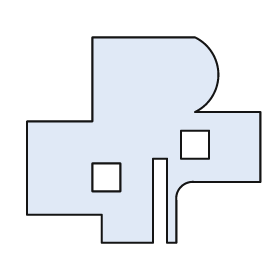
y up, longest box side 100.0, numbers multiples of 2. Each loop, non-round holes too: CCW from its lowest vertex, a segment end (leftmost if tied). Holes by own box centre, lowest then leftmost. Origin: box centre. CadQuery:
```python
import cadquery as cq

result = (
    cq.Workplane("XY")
    .moveTo(-18.0, -44.0)
    .lineTo(4.0, -44.0)
    .lineTo(4.0, -8.0)
    .lineTo(10.0, -8.0)
    .lineTo(10.0, -44.0)
    .lineTo(14.0, -44.0)
    .lineTo(14.0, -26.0)
    .threePointArc((16.0, -20.0), (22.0, -18.0))
    .lineTo(50.0, -18.0)
    .lineTo(50.0, 12.0)
    .lineTo(22.0, 12.0)
    .threePointArc((32.0, 28.0), (22.0, 44.0))
    .lineTo(-22.0, 44.0)
    .lineTo(-22.0, 8.0)
    .lineTo(-50.0, 8.0)
    .lineTo(-50.0, -32.0)
    .lineTo(-18.0, -32.0)
    .close()
    .moveTo(-22.0, -22.0)
    .lineTo(-10.0, -22.0)
    .lineTo(-10.0, -10.0)
    .lineTo(-22.0, -10.0)
    .close()
    .moveTo(16.0, -8.0)
    .lineTo(28.0, -8.0)
    .lineTo(28.0, 4.0)
    .lineTo(16.0, 4.0)
    .close()
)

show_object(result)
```